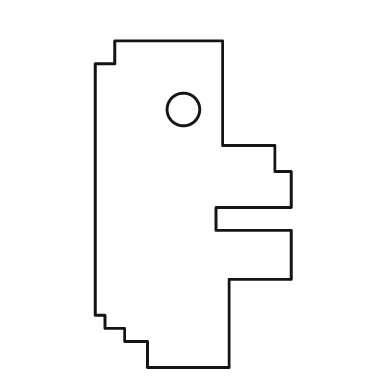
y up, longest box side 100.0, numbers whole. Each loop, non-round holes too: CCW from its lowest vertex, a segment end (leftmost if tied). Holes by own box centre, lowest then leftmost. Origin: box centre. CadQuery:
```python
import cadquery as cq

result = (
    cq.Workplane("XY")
    .moveTo(-14.0, -50.0)
    .lineTo(11.0, -50.0)
    .lineTo(11.0, -23.0)
    .lineTo(30.0, -23.0)
    .lineTo(30.0, -8.0)
    .lineTo(7.0, -8.0)
    .lineTo(7.0, -1.0)
    .lineTo(30.0, -1.0)
    .lineTo(30.0, 10.0)
    .lineTo(25.0, 10.0)
    .lineTo(25.0, 18.0)
    .lineTo(9.0, 18.0)
    .lineTo(9.0, 50.0)
    .lineTo(-24.0, 50.0)
    .lineTo(-24.0, 43.0)
    .lineTo(-30.0, 43.0)
    .lineTo(-30.0, -34.0)
    .lineTo(-27.0, -34.0)
    .lineTo(-27.0, -38.0)
    .lineTo(-21.0, -38.0)
    .lineTo(-21.0, -42.0)
    .lineTo(-14.0, -42.0)
    .close()
    .moveTo(-3.0, 29.0)
    .circle(5.0)
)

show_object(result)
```